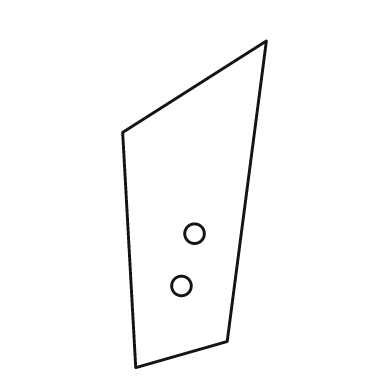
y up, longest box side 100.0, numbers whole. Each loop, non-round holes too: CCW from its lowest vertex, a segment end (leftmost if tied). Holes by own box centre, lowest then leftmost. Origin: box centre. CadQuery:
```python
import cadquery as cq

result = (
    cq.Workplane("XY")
    .moveTo(-18.0, -50.0)
    .lineTo(10.0, -42.0)
    .lineTo(22.0, 50.0)
    .lineTo(-22.0, 22.0)
    .close()
    .moveTo(-4.0, -25.0)
    .circle(3.0)
    .moveTo(0.0, -9.0)
    .circle(3.0)
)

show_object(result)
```